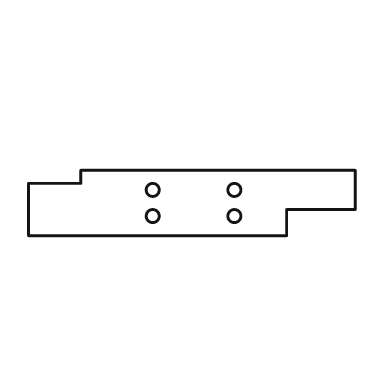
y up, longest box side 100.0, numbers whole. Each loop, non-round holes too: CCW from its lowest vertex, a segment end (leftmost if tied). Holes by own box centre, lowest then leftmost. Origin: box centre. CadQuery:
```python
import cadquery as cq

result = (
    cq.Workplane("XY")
    .moveTo(-50.0, -10.0)
    .lineTo(29.0, -10.0)
    .lineTo(29.0, -2.0)
    .lineTo(50.0, -2.0)
    .lineTo(50.0, 10.0)
    .lineTo(-34.0, 10.0)
    .lineTo(-34.0, 6.0)
    .lineTo(-50.0, 6.0)
    .close()
    .moveTo(-12.0, -4.0)
    .circle(2.0)
    .moveTo(13.0, -4.0)
    .circle(2.0)
    .moveTo(-12.0, 4.0)
    .circle(2.0)
    .moveTo(13.0, 4.0)
    .circle(2.0)
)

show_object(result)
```